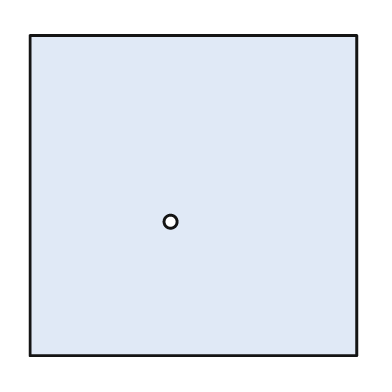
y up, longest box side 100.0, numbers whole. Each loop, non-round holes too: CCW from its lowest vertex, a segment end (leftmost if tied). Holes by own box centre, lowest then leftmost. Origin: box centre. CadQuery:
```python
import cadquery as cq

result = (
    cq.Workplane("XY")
    .moveTo(-50.0, -49.0)
    .lineTo(50.0, -49.0)
    .lineTo(50.0, 49.0)
    .lineTo(-50.0, 49.0)
    .close()
    .moveTo(-7.0, -8.0)
    .circle(2.0)
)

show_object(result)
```